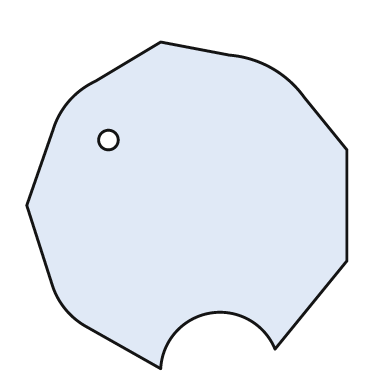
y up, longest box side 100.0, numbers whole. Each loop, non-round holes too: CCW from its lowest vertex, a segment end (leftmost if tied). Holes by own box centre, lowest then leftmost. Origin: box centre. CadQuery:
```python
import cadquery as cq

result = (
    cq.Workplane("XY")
    .moveTo(-8.0, -50.0)
    .threePointArc((7.0, -33.0), (27.0, -44.0))
    .lineTo(49.0, -17.0)
    .lineTo(49.0, 17.0)
    .lineTo(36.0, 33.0)
    .threePointArc((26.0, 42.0), (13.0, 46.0))
    .lineTo(-8.0, 50.0)
    .lineTo(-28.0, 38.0)
    .threePointArc((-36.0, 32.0), (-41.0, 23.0))
    .lineTo(-49.0, 0.0)
    .lineTo(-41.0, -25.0)
    .threePointArc((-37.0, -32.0), (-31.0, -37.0))
    .close()
    .moveTo(-24.0, 20.0)
    .circle(3.0)
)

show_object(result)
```